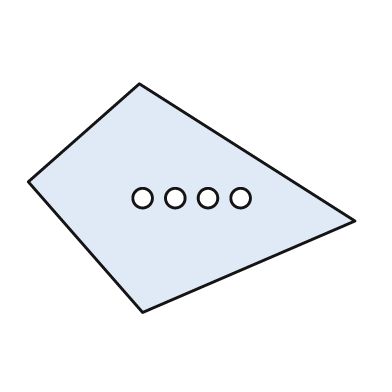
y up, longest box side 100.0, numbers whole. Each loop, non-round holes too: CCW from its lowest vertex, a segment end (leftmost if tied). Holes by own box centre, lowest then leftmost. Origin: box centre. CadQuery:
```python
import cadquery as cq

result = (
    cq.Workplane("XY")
    .moveTo(-15.0, -35.0)
    .lineTo(50.0, -7.0)
    .lineTo(-16.0, 35.0)
    .lineTo(-50.0, 5.0)
    .close()
    .moveTo(-15.0, 0.0)
    .circle(3.0)
    .moveTo(-5.0, 0.0)
    .circle(3.0)
    .moveTo(5.0, 0.0)
    .circle(3.0)
    .moveTo(15.0, 0.0)
    .circle(3.0)
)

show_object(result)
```